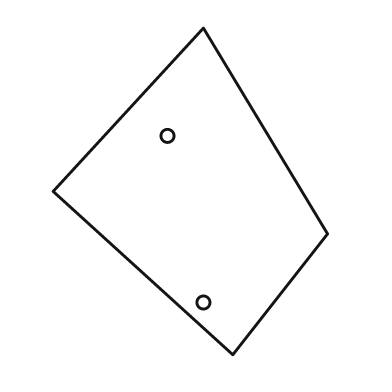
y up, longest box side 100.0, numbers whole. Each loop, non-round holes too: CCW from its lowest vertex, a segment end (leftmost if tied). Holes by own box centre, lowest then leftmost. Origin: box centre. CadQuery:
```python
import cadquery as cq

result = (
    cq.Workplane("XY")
    .moveTo(13.0, -50.0)
    .lineTo(42.0, -13.0)
    .lineTo(4.0, 50.0)
    .lineTo(-42.0, 0.0)
    .close()
    .moveTo(4.0, -34.0)
    .circle(2.0)
    .moveTo(-7.0, 17.0)
    .circle(2.0)
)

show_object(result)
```